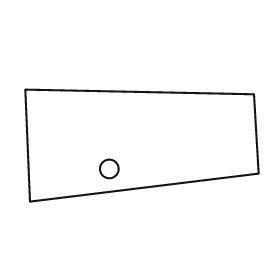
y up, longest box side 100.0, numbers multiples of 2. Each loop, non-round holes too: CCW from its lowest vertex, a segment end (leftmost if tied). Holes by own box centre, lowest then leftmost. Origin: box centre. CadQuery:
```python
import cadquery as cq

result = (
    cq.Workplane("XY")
    .moveTo(-48.0, -24.0)
    .lineTo(50.0, -12.0)
    .lineTo(48.0, 22.0)
    .lineTo(-50.0, 24.0)
    .close()
    .moveTo(-14.0, -10.0)
    .circle(4.0)
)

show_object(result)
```